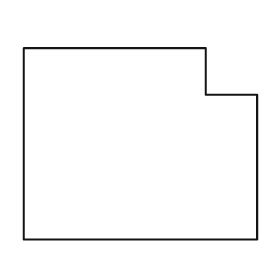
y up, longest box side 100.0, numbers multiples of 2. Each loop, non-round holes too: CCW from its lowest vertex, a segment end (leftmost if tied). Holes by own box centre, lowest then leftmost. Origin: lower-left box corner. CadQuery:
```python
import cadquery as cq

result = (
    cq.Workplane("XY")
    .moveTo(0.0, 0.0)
    .lineTo(100.0, 0.0)
    .lineTo(100.0, 62.0)
    .lineTo(78.0, 62.0)
    .lineTo(78.0, 82.0)
    .lineTo(0.0, 82.0)
    .close()
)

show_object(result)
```